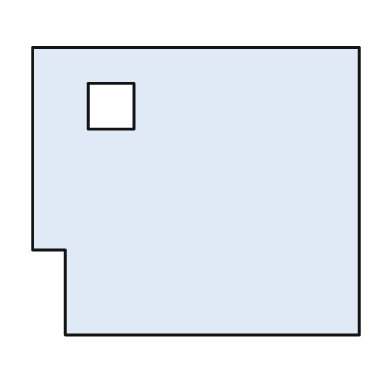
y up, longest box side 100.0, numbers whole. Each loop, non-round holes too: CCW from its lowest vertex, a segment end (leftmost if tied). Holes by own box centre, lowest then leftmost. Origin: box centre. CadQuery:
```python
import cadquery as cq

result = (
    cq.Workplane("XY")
    .moveTo(-40.0, -44.0)
    .lineTo(50.0, -44.0)
    .lineTo(50.0, 44.0)
    .lineTo(-50.0, 44.0)
    .lineTo(-50.0, -18.0)
    .lineTo(-40.0, -18.0)
    .close()
    .moveTo(-33.0, 19.0)
    .lineTo(-19.0, 19.0)
    .lineTo(-19.0, 33.0)
    .lineTo(-33.0, 33.0)
    .close()
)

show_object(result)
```